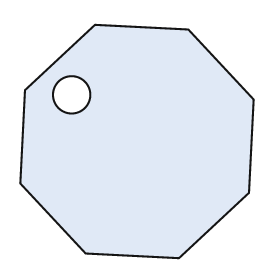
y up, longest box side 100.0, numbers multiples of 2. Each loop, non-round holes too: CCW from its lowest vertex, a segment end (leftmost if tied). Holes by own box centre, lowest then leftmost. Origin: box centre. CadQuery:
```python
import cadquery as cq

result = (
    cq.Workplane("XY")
    .moveTo(18.0, -50.0)
    .lineTo(48.0, -22.0)
    .lineTo(50.0, 18.0)
    .lineTo(22.0, 48.0)
    .lineTo(-18.0, 50.0)
    .lineTo(-48.0, 22.0)
    .lineTo(-50.0, -18.0)
    .lineTo(-22.0, -48.0)
    .close()
    .moveTo(-28.0, 20.0)
    .circle(8.0)
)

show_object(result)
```